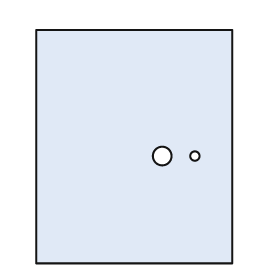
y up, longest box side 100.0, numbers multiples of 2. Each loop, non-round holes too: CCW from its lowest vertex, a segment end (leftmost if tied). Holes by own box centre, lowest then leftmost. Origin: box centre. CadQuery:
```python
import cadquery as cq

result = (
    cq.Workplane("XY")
    .moveTo(-42.0, -50.0)
    .lineTo(42.0, -50.0)
    .lineTo(42.0, 50.0)
    .lineTo(-42.0, 50.0)
    .close()
    .moveTo(12.0, -4.0)
    .circle(4.0)
    .moveTo(26.0, -4.0)
    .circle(2.0)
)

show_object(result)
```